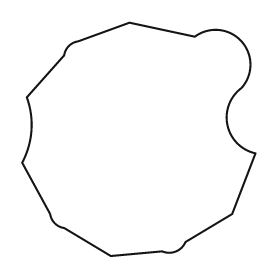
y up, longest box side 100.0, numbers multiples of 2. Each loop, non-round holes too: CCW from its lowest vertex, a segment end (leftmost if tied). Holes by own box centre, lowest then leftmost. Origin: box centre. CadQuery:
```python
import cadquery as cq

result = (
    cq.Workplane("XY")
    .moveTo(-12.0, -50.0)
    .lineTo(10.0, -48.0)
    .threePointArc((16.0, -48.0), (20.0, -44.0))
    .lineTo(40.0, -32.0)
    .lineTo(50.0, -6.0)
    .threePointArc((38.0, 6.0), (44.0, 22.0))
    .threePointArc((44.0, 42.0), (24.0, 44.0))
    .lineTo(-4.0, 50.0)
    .lineTo(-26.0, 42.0)
    .threePointArc((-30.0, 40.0), (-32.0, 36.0))
    .lineTo(-48.0, 18.0)
    .threePointArc((-46.0, 4.0), (-50.0, -10.0))
    .lineTo(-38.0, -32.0)
    .threePointArc((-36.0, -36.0), (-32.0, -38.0))
    .close()
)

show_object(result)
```